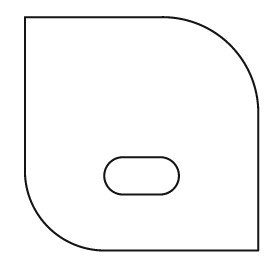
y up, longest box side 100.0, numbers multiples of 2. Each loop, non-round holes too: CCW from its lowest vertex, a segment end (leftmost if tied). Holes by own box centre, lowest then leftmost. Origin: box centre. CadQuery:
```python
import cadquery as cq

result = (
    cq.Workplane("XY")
    .moveTo(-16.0, -50.0)
    .lineTo(50.0, -50.0)
    .lineTo(50.0, 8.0)
    .threePointArc((38.0, 38.0), (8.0, 50.0))
    .lineTo(-50.0, 50.0)
    .lineTo(-50.0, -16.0)
    .threePointArc((-40.0, -40.0), (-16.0, -50.0))
    .close()
    .moveTo(-8.0, -26.0)
    .lineTo(8.0, -26.0)
    .threePointArc((16.0, -18.0), (8.0, -10.0))
    .lineTo(-8.0, -10.0)
    .threePointArc((-16.0, -18.0), (-8.0, -26.0))
    .close()
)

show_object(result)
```